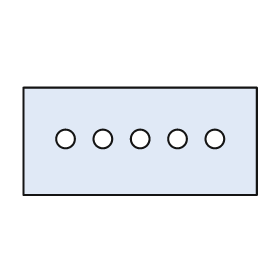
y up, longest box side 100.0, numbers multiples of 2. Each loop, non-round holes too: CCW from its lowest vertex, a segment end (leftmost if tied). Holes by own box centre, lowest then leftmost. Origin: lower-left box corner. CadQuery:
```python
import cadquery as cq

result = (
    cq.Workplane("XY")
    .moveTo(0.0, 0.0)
    .lineTo(100.0, 0.0)
    .lineTo(100.0, 46.0)
    .lineTo(0.0, 46.0)
    .close()
    .moveTo(18.0, 24.0)
    .circle(4.0)
    .moveTo(34.0, 24.0)
    .circle(4.0)
    .moveTo(50.0, 24.0)
    .circle(4.0)
    .moveTo(66.0, 24.0)
    .circle(4.0)
    .moveTo(82.0, 24.0)
    .circle(4.0)
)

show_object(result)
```